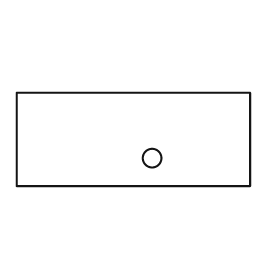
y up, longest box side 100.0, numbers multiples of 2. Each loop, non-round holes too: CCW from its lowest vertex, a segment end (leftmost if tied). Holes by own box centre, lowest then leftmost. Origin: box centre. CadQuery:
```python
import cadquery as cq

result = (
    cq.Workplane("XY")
    .moveTo(-50.0, -20.0)
    .lineTo(50.0, -20.0)
    .lineTo(50.0, 20.0)
    .lineTo(-50.0, 20.0)
    .close()
    .moveTo(8.0, -8.0)
    .circle(4.0)
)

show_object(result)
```